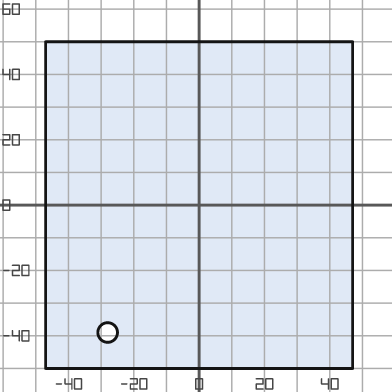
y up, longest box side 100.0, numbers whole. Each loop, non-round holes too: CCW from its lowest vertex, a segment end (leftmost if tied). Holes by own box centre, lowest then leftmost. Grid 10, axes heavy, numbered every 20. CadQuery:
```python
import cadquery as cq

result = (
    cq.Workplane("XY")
    .moveTo(-47.0, -50.0)
    .lineTo(47.0, -50.0)
    .lineTo(47.0, 50.0)
    .lineTo(-47.0, 50.0)
    .close()
    .moveTo(-28.0, -39.0)
    .circle(3.0)
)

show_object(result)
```